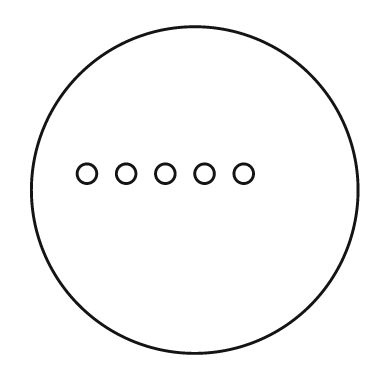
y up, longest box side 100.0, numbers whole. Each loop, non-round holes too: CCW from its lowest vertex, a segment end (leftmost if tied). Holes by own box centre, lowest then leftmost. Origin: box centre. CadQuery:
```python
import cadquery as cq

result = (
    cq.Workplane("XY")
    .moveTo(0.0, 0.0)
    .circle(50.0)
    .moveTo(-33.0, 5.0)
    .circle(3.0)
    .moveTo(-21.0, 5.0)
    .circle(3.0)
    .moveTo(-9.0, 5.0)
    .circle(3.0)
    .moveTo(3.0, 5.0)
    .circle(3.0)
    .moveTo(15.0, 5.0)
    .circle(3.0)
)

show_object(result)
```